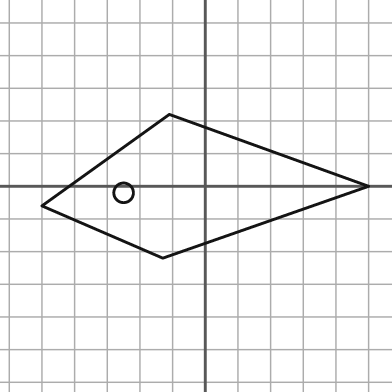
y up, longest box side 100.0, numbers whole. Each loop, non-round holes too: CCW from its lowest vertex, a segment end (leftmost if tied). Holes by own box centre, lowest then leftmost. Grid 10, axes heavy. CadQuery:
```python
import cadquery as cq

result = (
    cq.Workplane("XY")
    .moveTo(-13.0, -22.0)
    .lineTo(50.0, 0.0)
    .lineTo(-11.0, 22.0)
    .lineTo(-50.0, -6.0)
    .close()
    .moveTo(-25.0, -2.0)
    .circle(3.0)
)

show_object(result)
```